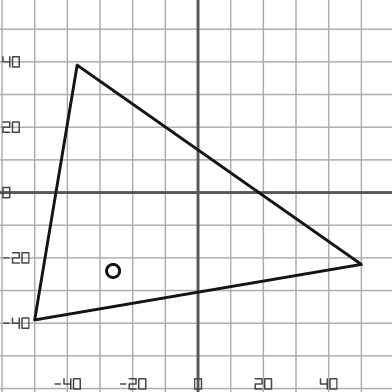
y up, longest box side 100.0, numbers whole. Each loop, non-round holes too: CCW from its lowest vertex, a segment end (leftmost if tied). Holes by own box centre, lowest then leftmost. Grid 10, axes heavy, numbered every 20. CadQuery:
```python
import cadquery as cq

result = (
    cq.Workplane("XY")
    .moveTo(-50.0, -39.0)
    .lineTo(50.0, -22.0)
    .lineTo(-37.0, 39.0)
    .close()
    .moveTo(-26.0, -24.0)
    .circle(2.0)
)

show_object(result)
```